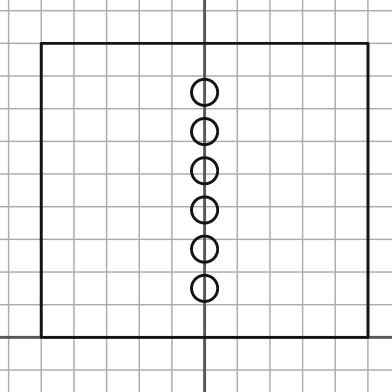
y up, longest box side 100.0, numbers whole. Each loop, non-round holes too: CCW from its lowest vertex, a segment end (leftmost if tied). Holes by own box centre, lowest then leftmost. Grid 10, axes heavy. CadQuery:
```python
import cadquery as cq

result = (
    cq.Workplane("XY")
    .moveTo(-50.0, 0.0)
    .lineTo(50.0, 0.0)
    .lineTo(50.0, 90.0)
    .lineTo(-50.0, 90.0)
    .close()
    .moveTo(0.0, 15.0)
    .circle(4.0)
    .moveTo(0.0, 27.0)
    .circle(4.0)
    .moveTo(0.0, 39.0)
    .circle(4.0)
    .moveTo(0.0, 51.0)
    .circle(4.0)
    .moveTo(0.0, 63.0)
    .circle(4.0)
    .moveTo(0.0, 75.0)
    .circle(4.0)
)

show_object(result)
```